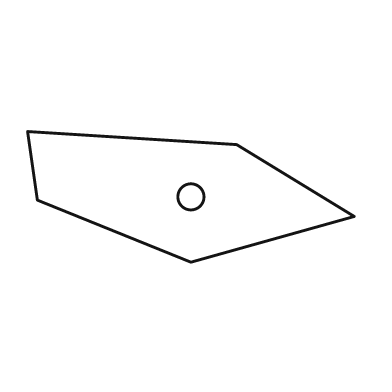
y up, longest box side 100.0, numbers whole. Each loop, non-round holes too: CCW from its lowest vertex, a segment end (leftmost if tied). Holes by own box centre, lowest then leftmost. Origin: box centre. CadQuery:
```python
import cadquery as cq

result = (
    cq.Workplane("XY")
    .moveTo(0.0, -20.0)
    .lineTo(50.0, -6.0)
    .lineTo(14.0, 16.0)
    .lineTo(-50.0, 20.0)
    .lineTo(-47.0, -1.0)
    .close()
    .moveTo(0.0, 0.0)
    .circle(4.0)
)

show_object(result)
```